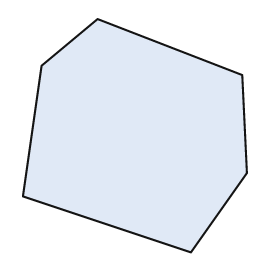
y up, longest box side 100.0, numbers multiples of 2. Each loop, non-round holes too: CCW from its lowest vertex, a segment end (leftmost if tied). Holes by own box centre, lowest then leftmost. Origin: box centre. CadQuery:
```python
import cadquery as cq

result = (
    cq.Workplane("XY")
    .moveTo(24.0, -50.0)
    .lineTo(48.0, -16.0)
    .lineTo(46.0, 26.0)
    .lineTo(-16.0, 50.0)
    .lineTo(-40.0, 30.0)
    .lineTo(-48.0, -26.0)
    .close()
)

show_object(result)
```